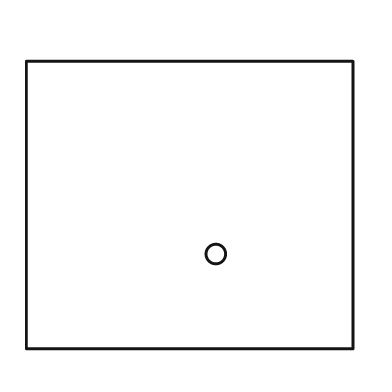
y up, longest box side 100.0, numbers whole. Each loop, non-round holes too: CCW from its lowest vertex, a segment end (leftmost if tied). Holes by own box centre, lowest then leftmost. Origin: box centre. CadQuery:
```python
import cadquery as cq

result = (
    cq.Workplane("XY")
    .moveTo(-50.0, -44.0)
    .lineTo(50.0, -44.0)
    .lineTo(50.0, 44.0)
    .lineTo(-50.0, 44.0)
    .close()
    .moveTo(8.0, -15.0)
    .circle(3.0)
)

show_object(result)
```